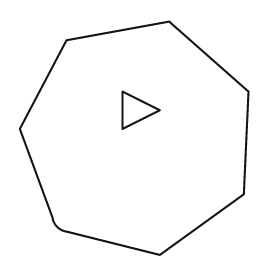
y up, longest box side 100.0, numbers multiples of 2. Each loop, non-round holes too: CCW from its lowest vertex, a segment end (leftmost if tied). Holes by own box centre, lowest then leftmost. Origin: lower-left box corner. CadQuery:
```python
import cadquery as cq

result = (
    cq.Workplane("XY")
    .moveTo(60.0, 0.0)
    .lineTo(96.0, 26.0)
    .lineTo(98.0, 70.0)
    .lineTo(64.0, 100.0)
    .lineTo(20.0, 92.0)
    .lineTo(0.0, 54.0)
    .lineTo(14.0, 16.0)
    .threePointArc((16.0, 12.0), (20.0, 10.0))
    .close()
    .moveTo(44.0, 54.0)
    .lineTo(60.0, 62.0)
    .lineTo(44.0, 70.0)
    .close()
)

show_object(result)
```